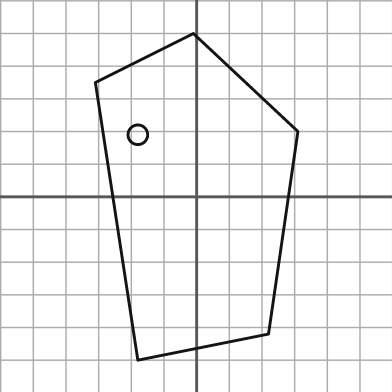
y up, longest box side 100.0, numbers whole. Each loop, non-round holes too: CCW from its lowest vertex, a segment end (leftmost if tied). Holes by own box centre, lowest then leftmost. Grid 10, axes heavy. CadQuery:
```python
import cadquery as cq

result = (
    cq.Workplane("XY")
    .moveTo(-18.0, -50.0)
    .lineTo(22.0, -42.0)
    .lineTo(31.0, 20.0)
    .lineTo(-1.0, 50.0)
    .lineTo(-31.0, 35.0)
    .close()
    .moveTo(-18.0, 19.0)
    .circle(3.0)
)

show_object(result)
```